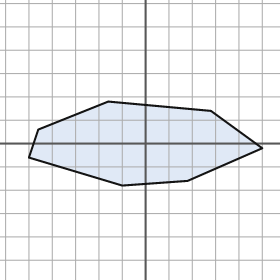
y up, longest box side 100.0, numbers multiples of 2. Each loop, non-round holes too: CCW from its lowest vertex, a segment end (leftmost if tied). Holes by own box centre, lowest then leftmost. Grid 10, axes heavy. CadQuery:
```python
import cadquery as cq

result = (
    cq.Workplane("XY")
    .moveTo(-10.0, -18.0)
    .lineTo(18.0, -16.0)
    .lineTo(50.0, -2.0)
    .lineTo(28.0, 14.0)
    .lineTo(-16.0, 18.0)
    .lineTo(-46.0, 6.0)
    .lineTo(-50.0, -6.0)
    .close()
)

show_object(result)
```